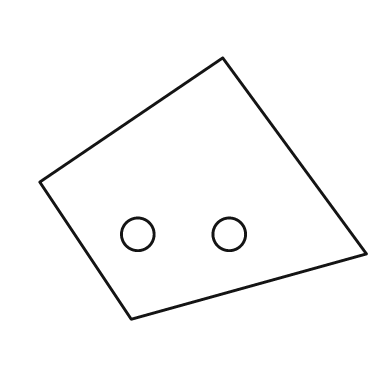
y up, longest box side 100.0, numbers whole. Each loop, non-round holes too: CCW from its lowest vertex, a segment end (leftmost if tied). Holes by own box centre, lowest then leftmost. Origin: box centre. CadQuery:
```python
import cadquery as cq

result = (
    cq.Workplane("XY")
    .moveTo(-22.0, -40.0)
    .lineTo(50.0, -20.0)
    .lineTo(6.0, 40.0)
    .lineTo(-50.0, 2.0)
    .close()
    .moveTo(-20.0, -14.0)
    .circle(5.0)
    .moveTo(8.0, -14.0)
    .circle(5.0)
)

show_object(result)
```